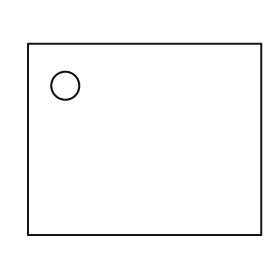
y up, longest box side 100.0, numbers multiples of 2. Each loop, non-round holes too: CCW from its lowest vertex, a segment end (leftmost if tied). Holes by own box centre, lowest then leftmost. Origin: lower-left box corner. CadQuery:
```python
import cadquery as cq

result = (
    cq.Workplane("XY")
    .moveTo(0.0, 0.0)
    .lineTo(100.0, 0.0)
    .lineTo(100.0, 82.0)
    .lineTo(0.0, 82.0)
    .close()
    .moveTo(16.0, 64.0)
    .circle(6.0)
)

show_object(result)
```